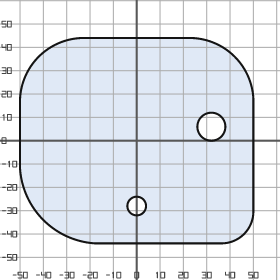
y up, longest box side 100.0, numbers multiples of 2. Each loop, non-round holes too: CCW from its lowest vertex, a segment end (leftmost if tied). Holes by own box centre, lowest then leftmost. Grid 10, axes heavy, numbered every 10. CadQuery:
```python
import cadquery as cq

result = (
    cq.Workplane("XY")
    .moveTo(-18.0, -44.0)
    .lineTo(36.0, -44.0)
    .threePointArc((46.0, -40.0), (50.0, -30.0))
    .lineTo(50.0, 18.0)
    .threePointArc((42.0, 36.0), (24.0, 44.0))
    .lineTo(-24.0, 44.0)
    .threePointArc((-42.0, 36.0), (-50.0, 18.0))
    .lineTo(-50.0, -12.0)
    .threePointArc((-40.0, -34.0), (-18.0, -44.0))
    .close()
    .moveTo(0.0, -28.0)
    .circle(4.0)
    .moveTo(32.0, 6.0)
    .circle(6.0)
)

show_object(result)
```